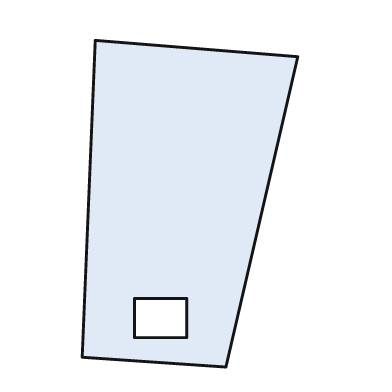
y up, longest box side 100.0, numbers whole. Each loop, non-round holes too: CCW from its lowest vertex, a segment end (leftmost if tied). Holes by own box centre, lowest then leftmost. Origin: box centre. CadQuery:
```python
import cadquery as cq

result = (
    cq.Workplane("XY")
    .moveTo(11.0, -50.0)
    .lineTo(33.0, 45.0)
    .lineTo(-29.0, 50.0)
    .lineTo(-33.0, -47.0)
    .close()
    .moveTo(-17.0, -41.0)
    .lineTo(-1.0, -41.0)
    .lineTo(-1.0, -29.0)
    .lineTo(-17.0, -29.0)
    .close()
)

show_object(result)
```